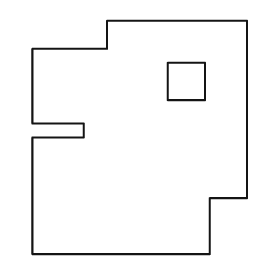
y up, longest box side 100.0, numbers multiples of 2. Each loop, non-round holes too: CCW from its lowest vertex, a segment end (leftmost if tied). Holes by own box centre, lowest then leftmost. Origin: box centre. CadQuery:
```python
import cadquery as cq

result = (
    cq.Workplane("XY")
    .moveTo(-46.0, -50.0)
    .lineTo(30.0, -50.0)
    .lineTo(30.0, -26.0)
    .lineTo(46.0, -26.0)
    .lineTo(46.0, 50.0)
    .lineTo(-14.0, 50.0)
    .lineTo(-14.0, 38.0)
    .lineTo(-46.0, 38.0)
    .lineTo(-46.0, 6.0)
    .lineTo(-24.0, 6.0)
    .lineTo(-24.0, 0.0)
    .lineTo(-46.0, 0.0)
    .close()
    .moveTo(12.0, 16.0)
    .lineTo(28.0, 16.0)
    .lineTo(28.0, 32.0)
    .lineTo(12.0, 32.0)
    .close()
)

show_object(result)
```